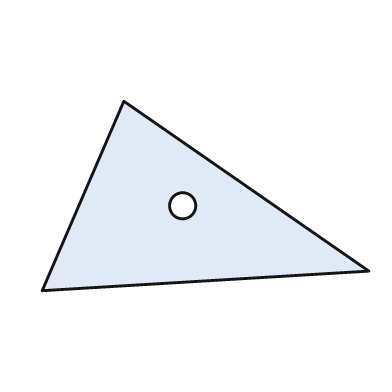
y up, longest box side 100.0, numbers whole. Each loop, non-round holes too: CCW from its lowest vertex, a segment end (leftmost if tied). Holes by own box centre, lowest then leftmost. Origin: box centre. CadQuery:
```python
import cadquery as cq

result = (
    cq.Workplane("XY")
    .moveTo(-50.0, -29.0)
    .lineTo(50.0, -23.0)
    .lineTo(-25.0, 29.0)
    .close()
    .moveTo(-7.0, -3.0)
    .circle(4.0)
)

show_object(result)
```